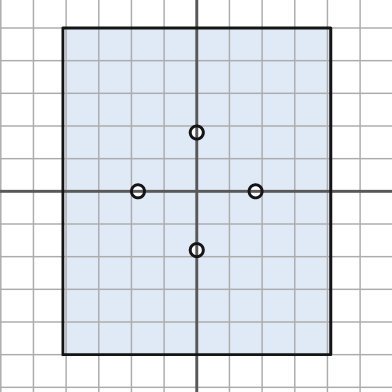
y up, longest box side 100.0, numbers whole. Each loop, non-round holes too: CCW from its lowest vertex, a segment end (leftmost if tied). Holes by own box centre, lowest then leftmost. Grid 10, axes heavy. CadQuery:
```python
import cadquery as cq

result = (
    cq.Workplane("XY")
    .moveTo(-41.0, -50.0)
    .lineTo(41.0, -50.0)
    .lineTo(41.0, 50.0)
    .lineTo(-41.0, 50.0)
    .close()
    .moveTo(0.0, -18.0)
    .circle(2.0)
    .moveTo(-18.0, 0.0)
    .circle(2.0)
    .moveTo(18.0, 0.0)
    .circle(2.0)
    .moveTo(0.0, 18.0)
    .circle(2.0)
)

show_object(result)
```